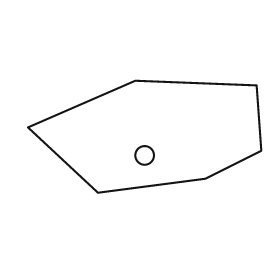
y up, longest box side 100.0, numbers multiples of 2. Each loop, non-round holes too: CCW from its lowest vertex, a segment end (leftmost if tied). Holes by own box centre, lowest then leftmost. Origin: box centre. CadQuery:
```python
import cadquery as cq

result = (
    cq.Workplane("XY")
    .moveTo(-20.0, -24.0)
    .lineTo(26.0, -18.0)
    .lineTo(50.0, -6.0)
    .lineTo(48.0, 22.0)
    .lineTo(-4.0, 24.0)
    .lineTo(-50.0, 4.0)
    .close()
    .moveTo(0.0, -8.0)
    .circle(4.0)
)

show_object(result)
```